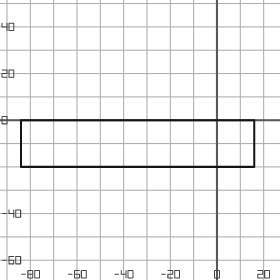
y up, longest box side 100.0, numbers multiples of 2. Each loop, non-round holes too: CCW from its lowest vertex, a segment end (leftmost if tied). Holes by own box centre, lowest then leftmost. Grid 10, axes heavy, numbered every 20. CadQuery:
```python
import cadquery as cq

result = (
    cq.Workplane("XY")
    .moveTo(-84.0, -20.0)
    .lineTo(16.0, -20.0)
    .lineTo(16.0, 0.0)
    .lineTo(-84.0, 0.0)
    .close()
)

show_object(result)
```